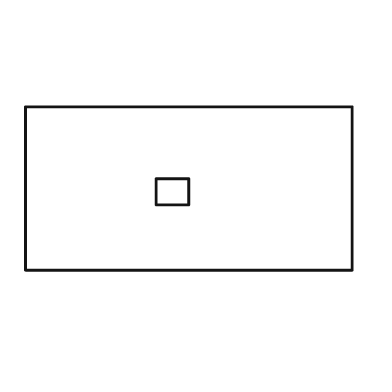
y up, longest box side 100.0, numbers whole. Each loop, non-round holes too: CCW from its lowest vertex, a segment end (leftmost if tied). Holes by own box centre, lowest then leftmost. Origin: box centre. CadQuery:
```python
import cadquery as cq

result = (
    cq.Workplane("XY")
    .moveTo(-50.0, -25.0)
    .lineTo(50.0, -25.0)
    .lineTo(50.0, 25.0)
    .lineTo(-50.0, 25.0)
    .close()
    .moveTo(-10.0, -5.0)
    .lineTo(0.0, -5.0)
    .lineTo(0.0, 3.0)
    .lineTo(-10.0, 3.0)
    .close()
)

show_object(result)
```